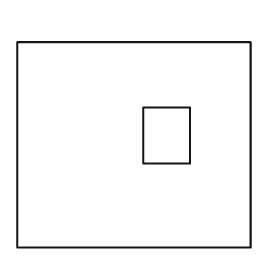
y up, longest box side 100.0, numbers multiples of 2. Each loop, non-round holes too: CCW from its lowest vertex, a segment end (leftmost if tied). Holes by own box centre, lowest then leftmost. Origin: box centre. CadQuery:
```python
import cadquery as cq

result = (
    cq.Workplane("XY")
    .moveTo(-50.0, -44.0)
    .lineTo(50.0, -44.0)
    .lineTo(50.0, 44.0)
    .lineTo(-50.0, 44.0)
    .close()
    .moveTo(4.0, -8.0)
    .lineTo(24.0, -8.0)
    .lineTo(24.0, 16.0)
    .lineTo(4.0, 16.0)
    .close()
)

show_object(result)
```